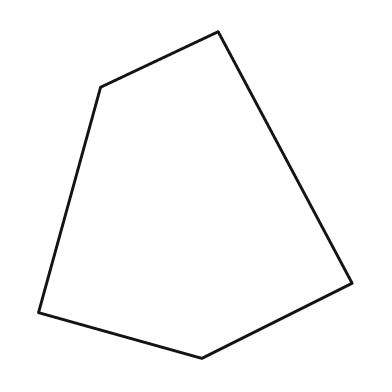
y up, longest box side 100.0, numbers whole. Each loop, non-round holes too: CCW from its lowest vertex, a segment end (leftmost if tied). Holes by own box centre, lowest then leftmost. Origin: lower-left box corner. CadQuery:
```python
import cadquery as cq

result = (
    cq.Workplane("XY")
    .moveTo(50.0, 0.0)
    .lineTo(96.0, 23.0)
    .lineTo(55.0, 100.0)
    .lineTo(19.0, 83.0)
    .lineTo(0.0, 14.0)
    .close()
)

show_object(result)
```